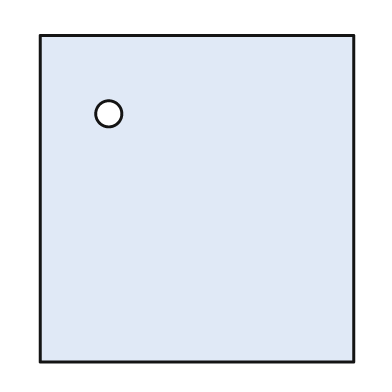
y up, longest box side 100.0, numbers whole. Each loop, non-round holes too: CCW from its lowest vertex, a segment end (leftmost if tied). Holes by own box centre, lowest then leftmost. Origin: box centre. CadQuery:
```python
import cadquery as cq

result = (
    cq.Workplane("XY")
    .moveTo(-48.0, -50.0)
    .lineTo(48.0, -50.0)
    .lineTo(48.0, 50.0)
    .lineTo(-48.0, 50.0)
    .close()
    .moveTo(-27.0, 26.0)
    .circle(4.0)
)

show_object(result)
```